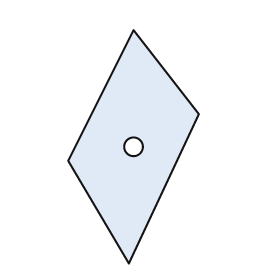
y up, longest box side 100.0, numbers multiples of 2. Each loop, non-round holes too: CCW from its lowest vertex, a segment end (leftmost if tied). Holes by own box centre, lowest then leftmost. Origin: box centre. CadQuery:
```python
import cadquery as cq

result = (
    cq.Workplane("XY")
    .moveTo(-2.0, -50.0)
    .lineTo(28.0, 14.0)
    .lineTo(0.0, 50.0)
    .lineTo(-28.0, -6.0)
    .close()
    .moveTo(0.0, 0.0)
    .circle(4.0)
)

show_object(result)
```